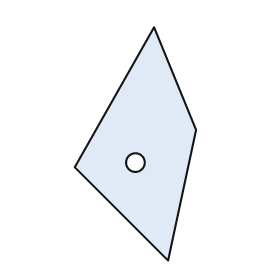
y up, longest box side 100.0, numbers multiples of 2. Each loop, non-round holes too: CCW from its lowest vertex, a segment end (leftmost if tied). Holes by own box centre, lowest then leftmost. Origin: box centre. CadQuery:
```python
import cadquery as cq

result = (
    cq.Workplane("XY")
    .moveTo(14.0, -50.0)
    .lineTo(26.0, 6.0)
    .lineTo(8.0, 50.0)
    .lineTo(-26.0, -10.0)
    .close()
    .moveTo(0.0, -8.0)
    .circle(4.0)
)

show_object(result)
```